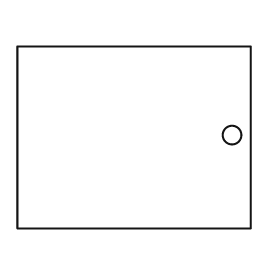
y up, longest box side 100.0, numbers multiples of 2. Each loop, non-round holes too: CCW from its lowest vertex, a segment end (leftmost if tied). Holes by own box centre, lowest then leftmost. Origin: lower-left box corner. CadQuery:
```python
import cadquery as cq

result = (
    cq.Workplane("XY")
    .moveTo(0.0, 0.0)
    .lineTo(100.0, 0.0)
    .lineTo(100.0, 78.0)
    .lineTo(0.0, 78.0)
    .close()
    .moveTo(92.0, 40.0)
    .circle(4.0)
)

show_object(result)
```